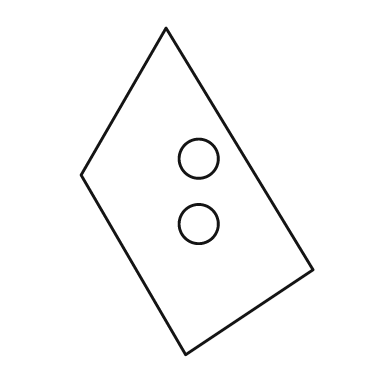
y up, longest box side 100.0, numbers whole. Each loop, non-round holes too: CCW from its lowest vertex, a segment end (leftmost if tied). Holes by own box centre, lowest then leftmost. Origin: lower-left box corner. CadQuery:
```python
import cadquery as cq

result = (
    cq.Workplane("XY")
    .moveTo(32.0, 0.0)
    .lineTo(71.0, 26.0)
    .lineTo(26.0, 100.0)
    .lineTo(0.0, 55.0)
    .close()
    .moveTo(36.0, 40.0)
    .circle(6.0)
    .moveTo(36.0, 60.0)
    .circle(6.0)
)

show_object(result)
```